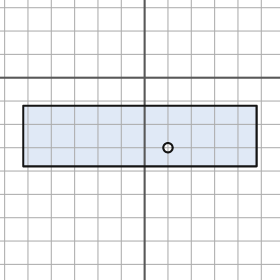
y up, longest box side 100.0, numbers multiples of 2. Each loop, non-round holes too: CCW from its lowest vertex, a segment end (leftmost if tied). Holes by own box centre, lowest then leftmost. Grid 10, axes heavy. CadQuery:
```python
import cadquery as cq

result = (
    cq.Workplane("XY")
    .moveTo(-52.0, -38.0)
    .lineTo(48.0, -38.0)
    .lineTo(48.0, -12.0)
    .lineTo(-52.0, -12.0)
    .close()
    .moveTo(10.0, -30.0)
    .circle(2.0)
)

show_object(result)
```